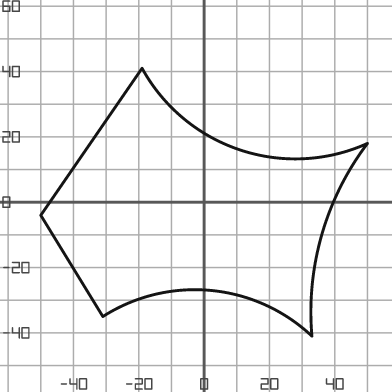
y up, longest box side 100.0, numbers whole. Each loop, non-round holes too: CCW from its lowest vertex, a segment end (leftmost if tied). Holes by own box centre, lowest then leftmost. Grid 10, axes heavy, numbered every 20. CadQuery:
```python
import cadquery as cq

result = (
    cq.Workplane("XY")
    .moveTo(33.0, -41.0)
    .threePointArc((36.0, -10.0), (50.0, 18.0))
    .threePointArc((11.0, 16.0), (-19.0, 41.0))
    .lineTo(-50.0, -4.0)
    .lineTo(-31.0, -35.0)
    .threePointArc((2.0, -27.0), (33.0, -41.0))
    .close()
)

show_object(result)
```